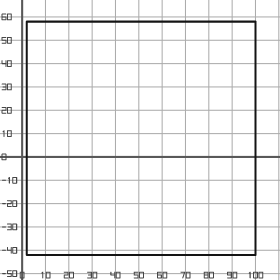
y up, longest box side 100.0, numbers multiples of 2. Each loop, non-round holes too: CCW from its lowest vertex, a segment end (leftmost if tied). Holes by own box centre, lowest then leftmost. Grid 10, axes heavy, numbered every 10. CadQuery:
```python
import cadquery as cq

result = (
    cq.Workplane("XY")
    .moveTo(2.0, -42.0)
    .lineTo(100.0, -42.0)
    .lineTo(100.0, 58.0)
    .lineTo(2.0, 58.0)
    .close()
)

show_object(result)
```